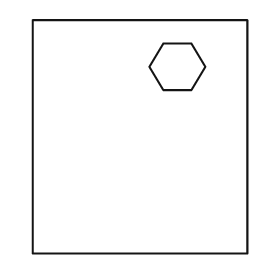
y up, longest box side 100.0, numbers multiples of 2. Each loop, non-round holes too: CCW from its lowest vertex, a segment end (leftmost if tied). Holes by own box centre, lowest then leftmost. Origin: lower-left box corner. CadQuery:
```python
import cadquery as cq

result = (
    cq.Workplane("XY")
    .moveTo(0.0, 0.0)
    .lineTo(92.0, 0.0)
    .lineTo(92.0, 100.0)
    .lineTo(0.0, 100.0)
    .close()
    .moveTo(56.0, 70.0)
    .lineTo(68.0, 70.0)
    .lineTo(74.0, 80.0)
    .lineTo(68.0, 90.0)
    .lineTo(56.0, 90.0)
    .lineTo(50.0, 80.0)
    .close()
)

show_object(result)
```